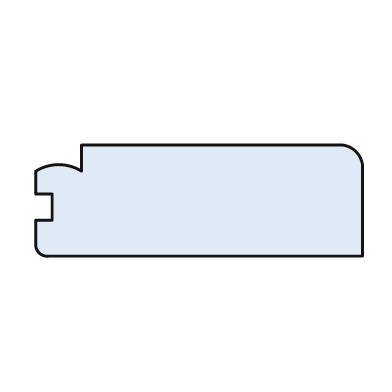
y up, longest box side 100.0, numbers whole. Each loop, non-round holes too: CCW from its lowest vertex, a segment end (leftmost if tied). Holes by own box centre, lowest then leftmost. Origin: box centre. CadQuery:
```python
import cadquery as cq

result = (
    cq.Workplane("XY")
    .moveTo(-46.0, -17.0)
    .lineTo(50.0, -17.0)
    .lineTo(50.0, 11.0)
    .threePointArc((48.0, 15.0), (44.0, 17.0))
    .lineTo(-36.0, 17.0)
    .lineTo(-36.0, 9.0)
    .threePointArc((-43.0, 11.0), (-50.0, 9.0))
    .lineTo(-50.0, 2.0)
    .lineTo(-45.0, 2.0)
    .lineTo(-45.0, -6.0)
    .lineTo(-50.0, -6.0)
    .lineTo(-50.0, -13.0)
    .threePointArc((-49.0, -16.0), (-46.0, -17.0))
    .close()
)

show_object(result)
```